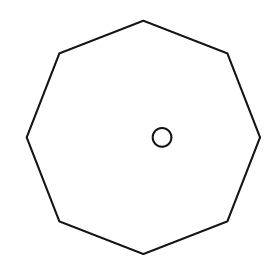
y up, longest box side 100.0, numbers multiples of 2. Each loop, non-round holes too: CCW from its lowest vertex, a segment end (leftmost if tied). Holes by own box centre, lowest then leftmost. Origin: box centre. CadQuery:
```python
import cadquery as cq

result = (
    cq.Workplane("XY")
    .moveTo(0.0, -50.0)
    .lineTo(36.0, -36.0)
    .lineTo(50.0, 0.0)
    .lineTo(36.0, 36.0)
    .lineTo(0.0, 50.0)
    .lineTo(-36.0, 36.0)
    .lineTo(-50.0, 0.0)
    .lineTo(-36.0, -36.0)
    .close()
    .moveTo(8.0, 0.0)
    .circle(4.0)
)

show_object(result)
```